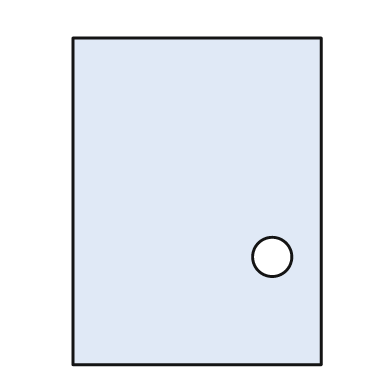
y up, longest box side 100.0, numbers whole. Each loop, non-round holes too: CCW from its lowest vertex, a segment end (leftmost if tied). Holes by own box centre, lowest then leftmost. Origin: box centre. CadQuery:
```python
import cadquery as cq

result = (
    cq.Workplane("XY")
    .moveTo(-38.0, -50.0)
    .lineTo(38.0, -50.0)
    .lineTo(38.0, 50.0)
    .lineTo(-38.0, 50.0)
    .close()
    .moveTo(23.0, -17.0)
    .circle(6.0)
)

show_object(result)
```